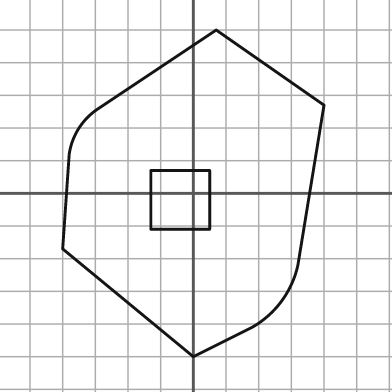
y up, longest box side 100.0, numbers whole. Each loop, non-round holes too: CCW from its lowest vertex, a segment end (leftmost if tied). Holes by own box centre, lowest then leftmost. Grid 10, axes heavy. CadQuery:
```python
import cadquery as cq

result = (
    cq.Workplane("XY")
    .moveTo(0.0, -50.0)
    .lineTo(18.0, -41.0)
    .threePointArc((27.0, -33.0), (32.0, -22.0))
    .lineTo(40.0, 27.0)
    .lineTo(7.0, 50.0)
    .lineTo(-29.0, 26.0)
    .threePointArc((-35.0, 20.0), (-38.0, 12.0))
    .lineTo(-40.0, -17.0)
    .close()
    .moveTo(-13.0, -11.0)
    .lineTo(5.0, -11.0)
    .lineTo(5.0, 7.0)
    .lineTo(-13.0, 7.0)
    .close()
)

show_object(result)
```